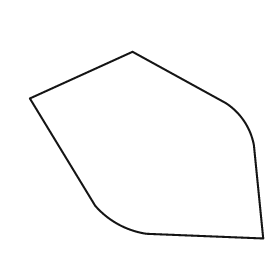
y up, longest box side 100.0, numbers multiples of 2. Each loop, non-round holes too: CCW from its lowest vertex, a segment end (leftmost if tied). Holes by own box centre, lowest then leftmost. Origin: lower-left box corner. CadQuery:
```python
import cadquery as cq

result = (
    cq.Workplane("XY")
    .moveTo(100.0, 0.0)
    .lineTo(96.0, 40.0)
    .threePointArc((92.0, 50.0), (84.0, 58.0))
    .lineTo(44.0, 80.0)
    .lineTo(0.0, 60.0)
    .lineTo(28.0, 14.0)
    .threePointArc((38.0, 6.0), (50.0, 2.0))
    .close()
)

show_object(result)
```